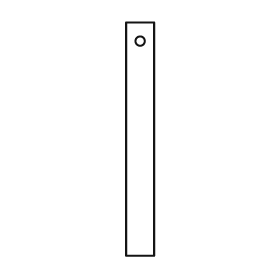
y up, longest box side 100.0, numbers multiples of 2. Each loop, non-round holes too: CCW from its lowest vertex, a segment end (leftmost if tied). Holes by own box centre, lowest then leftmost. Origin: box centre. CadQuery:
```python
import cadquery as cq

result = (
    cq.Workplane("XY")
    .moveTo(-6.0, -50.0)
    .lineTo(6.0, -50.0)
    .lineTo(6.0, 50.0)
    .lineTo(-6.0, 50.0)
    .close()
    .moveTo(0.0, 42.0)
    .circle(2.0)
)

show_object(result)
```